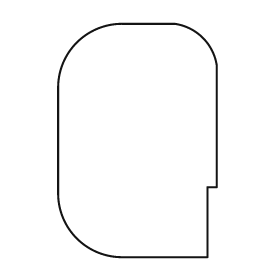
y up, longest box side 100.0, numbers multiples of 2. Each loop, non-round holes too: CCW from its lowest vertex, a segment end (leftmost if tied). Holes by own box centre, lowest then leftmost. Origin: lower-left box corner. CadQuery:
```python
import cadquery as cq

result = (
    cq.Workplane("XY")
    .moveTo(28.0, 0.0)
    .lineTo(64.0, 0.0)
    .lineTo(64.0, 30.0)
    .lineTo(68.0, 30.0)
    .lineTo(68.0, 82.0)
    .threePointArc((62.0, 94.0), (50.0, 100.0))
    .lineTo(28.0, 100.0)
    .threePointArc((8.0, 92.0), (0.0, 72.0))
    .lineTo(0.0, 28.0)
    .threePointArc((8.0, 8.0), (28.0, 0.0))
    .close()
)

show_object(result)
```